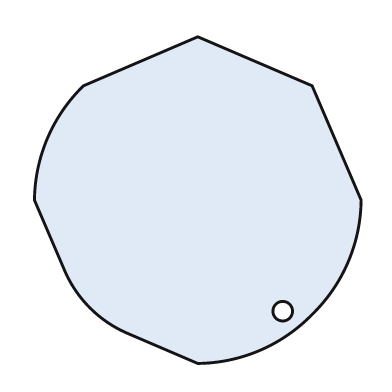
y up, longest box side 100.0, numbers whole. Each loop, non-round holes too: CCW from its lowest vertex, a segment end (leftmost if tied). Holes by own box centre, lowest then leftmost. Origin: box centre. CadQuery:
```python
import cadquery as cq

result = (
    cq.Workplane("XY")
    .moveTo(0.0, -50.0)
    .threePointArc((19.0, -46.0), (35.0, -35.0))
    .threePointArc((46.0, -19.0), (50.0, 0.0))
    .lineTo(35.0, 35.0)
    .lineTo(0.0, 50.0)
    .lineTo(-35.0, 35.0)
    .threePointArc((-46.0, 19.0), (-50.0, 0.0))
    .lineTo(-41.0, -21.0)
    .threePointArc((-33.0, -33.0), (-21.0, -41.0))
    .close()
    .moveTo(26.0, -34.0)
    .circle(3.0)
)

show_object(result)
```